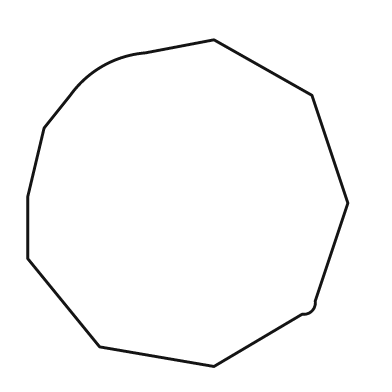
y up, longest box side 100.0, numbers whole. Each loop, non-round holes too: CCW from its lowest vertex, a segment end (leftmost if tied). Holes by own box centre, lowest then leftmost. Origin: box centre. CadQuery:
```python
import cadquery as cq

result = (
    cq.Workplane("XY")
    .moveTo(8.0, -50.0)
    .lineTo(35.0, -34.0)
    .threePointArc((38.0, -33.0), (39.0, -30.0))
    .lineTo(49.0, 0.0)
    .lineTo(38.0, 33.0)
    .lineTo(8.0, 50.0)
    .lineTo(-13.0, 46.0)
    .threePointArc((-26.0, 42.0), (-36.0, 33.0))
    .lineTo(-44.0, 23.0)
    .lineTo(-49.0, 2.0)
    .lineTo(-49.0, -17.0)
    .lineTo(-27.0, -44.0)
    .close()
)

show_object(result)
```